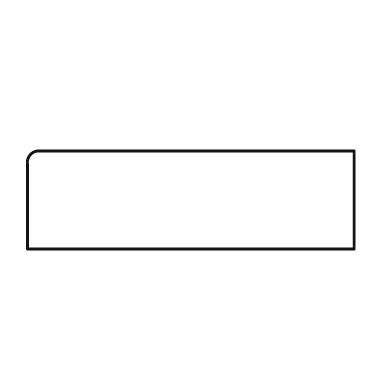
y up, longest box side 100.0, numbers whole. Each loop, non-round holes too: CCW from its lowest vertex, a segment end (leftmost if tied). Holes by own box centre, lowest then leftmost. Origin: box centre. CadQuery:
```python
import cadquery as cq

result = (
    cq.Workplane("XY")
    .moveTo(-50.0, -15.0)
    .lineTo(50.0, -15.0)
    .lineTo(50.0, 15.0)
    .lineTo(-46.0, 15.0)
    .threePointArc((-49.0, 14.0), (-50.0, 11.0))
    .close()
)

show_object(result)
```